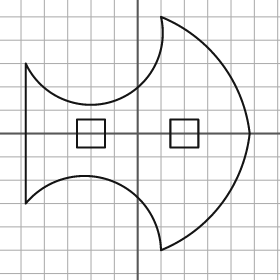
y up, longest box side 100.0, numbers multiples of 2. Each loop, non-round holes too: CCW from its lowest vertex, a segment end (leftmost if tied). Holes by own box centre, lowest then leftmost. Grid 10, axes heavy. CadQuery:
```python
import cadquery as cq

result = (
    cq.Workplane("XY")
    .moveTo(10.0, -50.0)
    .threePointArc((36.0, -30.0), (48.0, 0.0))
    .threePointArc((36.0, 30.0), (10.0, 50.0))
    .threePointArc((-10.0, 14.0), (-48.0, 30.0))
    .lineTo(-48.0, -30.0)
    .threePointArc((-12.0, -20.0), (10.0, -50.0))
    .close()
    .moveTo(-26.0, -6.0)
    .lineTo(-14.0, -6.0)
    .lineTo(-14.0, 6.0)
    .lineTo(-26.0, 6.0)
    .close()
    .moveTo(14.0, -6.0)
    .lineTo(26.0, -6.0)
    .lineTo(26.0, 6.0)
    .lineTo(14.0, 6.0)
    .close()
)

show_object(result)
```